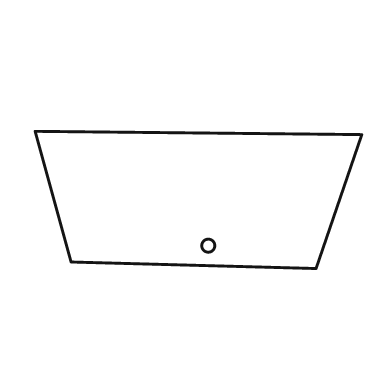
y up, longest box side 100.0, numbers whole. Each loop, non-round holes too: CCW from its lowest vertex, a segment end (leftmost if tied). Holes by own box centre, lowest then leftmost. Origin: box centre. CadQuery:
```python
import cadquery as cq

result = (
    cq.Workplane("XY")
    .moveTo(36.0, -21.0)
    .lineTo(50.0, 20.0)
    .lineTo(-50.0, 21.0)
    .lineTo(-39.0, -19.0)
    .close()
    .moveTo(3.0, -14.0)
    .circle(2.0)
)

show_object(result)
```